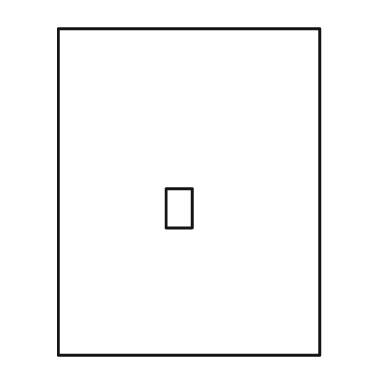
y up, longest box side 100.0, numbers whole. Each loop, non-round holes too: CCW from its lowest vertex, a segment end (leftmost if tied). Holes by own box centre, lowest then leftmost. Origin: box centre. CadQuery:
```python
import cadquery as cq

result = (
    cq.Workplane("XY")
    .moveTo(-40.0, -50.0)
    .lineTo(40.0, -50.0)
    .lineTo(40.0, 50.0)
    .lineTo(-40.0, 50.0)
    .close()
    .moveTo(-7.0, -11.0)
    .lineTo(1.0, -11.0)
    .lineTo(1.0, 1.0)
    .lineTo(-7.0, 1.0)
    .close()
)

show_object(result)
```